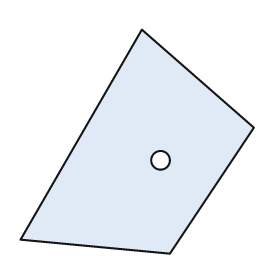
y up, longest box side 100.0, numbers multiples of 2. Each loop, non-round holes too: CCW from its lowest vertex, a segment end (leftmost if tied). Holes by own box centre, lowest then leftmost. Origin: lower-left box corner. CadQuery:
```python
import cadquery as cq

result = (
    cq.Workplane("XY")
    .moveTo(64.0, 0.0)
    .lineTo(100.0, 54.0)
    .lineTo(52.0, 96.0)
    .lineTo(0.0, 6.0)
    .close()
    .moveTo(60.0, 40.0)
    .circle(4.0)
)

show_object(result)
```